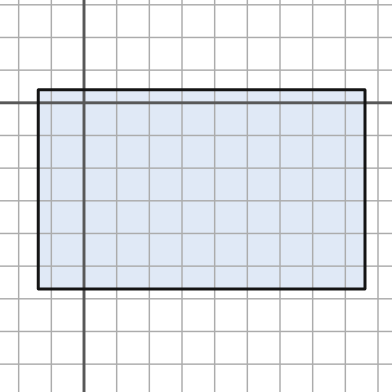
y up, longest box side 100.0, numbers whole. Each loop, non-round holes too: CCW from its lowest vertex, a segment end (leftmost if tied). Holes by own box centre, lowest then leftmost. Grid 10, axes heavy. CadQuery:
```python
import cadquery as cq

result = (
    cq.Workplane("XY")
    .moveTo(-14.0, -57.0)
    .lineTo(86.0, -57.0)
    .lineTo(86.0, 4.0)
    .lineTo(-14.0, 4.0)
    .close()
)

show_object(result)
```